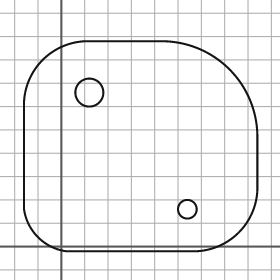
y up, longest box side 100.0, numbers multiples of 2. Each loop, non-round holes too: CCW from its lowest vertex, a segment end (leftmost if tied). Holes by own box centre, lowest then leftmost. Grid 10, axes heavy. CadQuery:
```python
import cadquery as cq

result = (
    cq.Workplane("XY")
    .moveTo(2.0, -2.0)
    .lineTo(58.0, -2.0)
    .threePointArc((76.0, 6.0), (84.0, 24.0))
    .lineTo(84.0, 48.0)
    .threePointArc((72.0, 76.0), (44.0, 88.0))
    .lineTo(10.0, 88.0)
    .threePointArc((-8.0, 80.0), (-16.0, 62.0))
    .lineTo(-16.0, 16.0)
    .threePointArc((-10.0, 4.0), (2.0, -2.0))
    .close()
    .moveTo(54.0, 16.0)
    .circle(4.0)
    .moveTo(12.0, 66.0)
    .circle(6.0)
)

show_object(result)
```